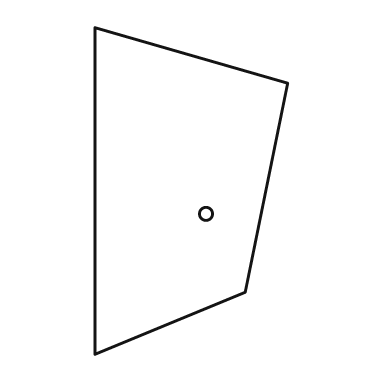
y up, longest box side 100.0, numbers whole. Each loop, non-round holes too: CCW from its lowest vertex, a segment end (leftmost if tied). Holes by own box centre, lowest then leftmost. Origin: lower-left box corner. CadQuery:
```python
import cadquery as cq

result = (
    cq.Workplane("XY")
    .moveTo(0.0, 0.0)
    .lineTo(46.0, 19.0)
    .lineTo(59.0, 83.0)
    .lineTo(0.0, 100.0)
    .close()
    .moveTo(34.0, 43.0)
    .circle(2.0)
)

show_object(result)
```